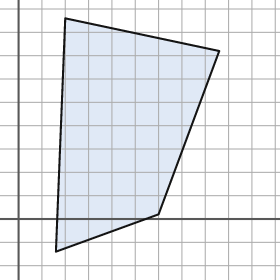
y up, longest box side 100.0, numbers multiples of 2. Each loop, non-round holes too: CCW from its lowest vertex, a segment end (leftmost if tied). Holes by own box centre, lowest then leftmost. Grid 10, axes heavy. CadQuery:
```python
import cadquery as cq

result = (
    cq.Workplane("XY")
    .moveTo(16.0, -14.0)
    .lineTo(60.0, 2.0)
    .lineTo(86.0, 72.0)
    .lineTo(20.0, 86.0)
    .close()
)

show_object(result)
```